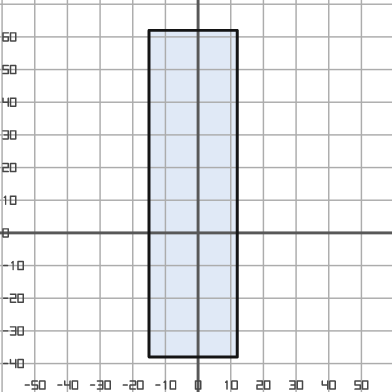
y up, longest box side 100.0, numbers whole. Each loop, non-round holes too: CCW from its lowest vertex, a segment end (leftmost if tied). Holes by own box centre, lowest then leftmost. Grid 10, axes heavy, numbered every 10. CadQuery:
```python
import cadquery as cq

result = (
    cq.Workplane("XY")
    .moveTo(-15.0, -38.0)
    .lineTo(12.0, -38.0)
    .lineTo(12.0, 62.0)
    .lineTo(-15.0, 62.0)
    .close()
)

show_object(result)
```